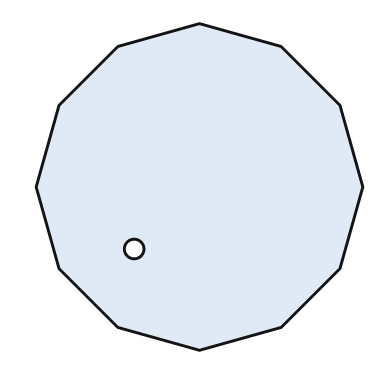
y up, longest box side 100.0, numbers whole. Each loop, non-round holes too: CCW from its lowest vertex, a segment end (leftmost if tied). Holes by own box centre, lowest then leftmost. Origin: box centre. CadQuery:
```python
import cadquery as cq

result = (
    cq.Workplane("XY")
    .moveTo(0.0, -50.0)
    .lineTo(25.0, -43.0)
    .lineTo(43.0, -25.0)
    .lineTo(50.0, 0.0)
    .lineTo(43.0, 25.0)
    .lineTo(25.0, 43.0)
    .lineTo(0.0, 50.0)
    .lineTo(-25.0, 43.0)
    .lineTo(-43.0, 25.0)
    .lineTo(-50.0, 0.0)
    .lineTo(-43.0, -25.0)
    .lineTo(-25.0, -43.0)
    .close()
    .moveTo(-20.0, -19.0)
    .circle(3.0)
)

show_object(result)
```